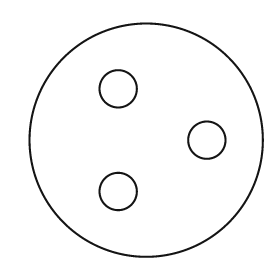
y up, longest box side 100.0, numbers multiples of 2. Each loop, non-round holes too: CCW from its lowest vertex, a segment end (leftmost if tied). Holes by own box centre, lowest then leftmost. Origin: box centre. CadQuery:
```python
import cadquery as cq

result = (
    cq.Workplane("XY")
    .moveTo(0.0, 0.0)
    .circle(50.0)
    .moveTo(-12.0, -22.0)
    .circle(8.0)
    .moveTo(26.0, 0.0)
    .circle(8.0)
    .moveTo(-12.0, 22.0)
    .circle(8.0)
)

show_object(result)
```